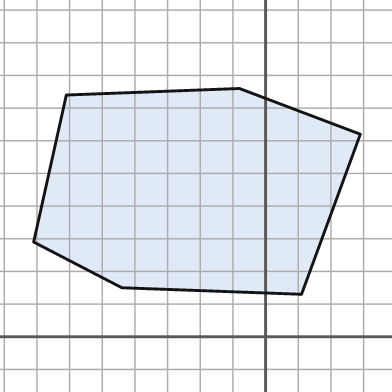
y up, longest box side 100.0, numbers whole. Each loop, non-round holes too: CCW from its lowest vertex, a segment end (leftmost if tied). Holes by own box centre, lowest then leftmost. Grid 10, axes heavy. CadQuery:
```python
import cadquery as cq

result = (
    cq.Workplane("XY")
    .moveTo(11.0, 13.0)
    .lineTo(29.0, 62.0)
    .lineTo(-8.0, 76.0)
    .lineTo(-61.0, 74.0)
    .lineTo(-71.0, 29.0)
    .lineTo(-44.0, 15.0)
    .close()
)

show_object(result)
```